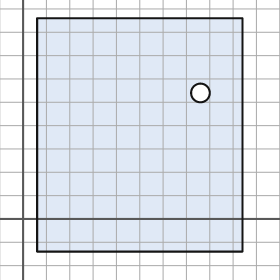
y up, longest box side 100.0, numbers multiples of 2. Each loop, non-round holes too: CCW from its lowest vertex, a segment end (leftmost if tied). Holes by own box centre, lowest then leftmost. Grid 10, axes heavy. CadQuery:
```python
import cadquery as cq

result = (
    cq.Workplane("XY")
    .moveTo(6.0, -14.0)
    .lineTo(94.0, -14.0)
    .lineTo(94.0, 86.0)
    .lineTo(6.0, 86.0)
    .close()
    .moveTo(76.0, 54.0)
    .circle(4.0)
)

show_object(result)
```